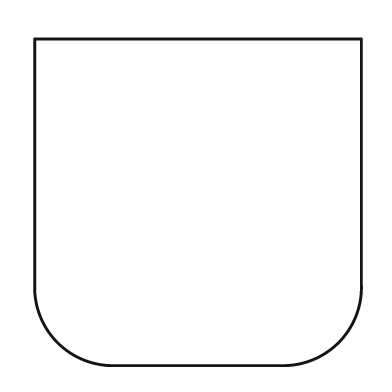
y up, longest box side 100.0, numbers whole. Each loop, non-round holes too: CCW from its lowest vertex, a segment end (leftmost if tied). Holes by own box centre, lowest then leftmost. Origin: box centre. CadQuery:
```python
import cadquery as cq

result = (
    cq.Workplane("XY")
    .moveTo(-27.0, -50.0)
    .lineTo(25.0, -50.0)
    .threePointArc((43.0, -43.0), (50.0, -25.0))
    .lineTo(50.0, 50.0)
    .lineTo(-50.0, 50.0)
    .lineTo(-50.0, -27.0)
    .threePointArc((-43.0, -43.0), (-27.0, -50.0))
    .close()
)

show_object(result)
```